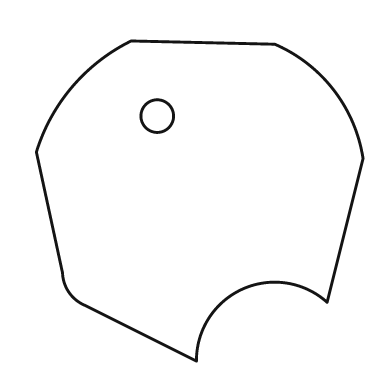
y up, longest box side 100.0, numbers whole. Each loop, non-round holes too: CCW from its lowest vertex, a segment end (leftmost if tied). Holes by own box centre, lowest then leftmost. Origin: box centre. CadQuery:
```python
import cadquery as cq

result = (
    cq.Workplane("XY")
    .moveTo(-1.0, -49.0)
    .threePointArc((13.0, -27.0), (39.0, -31.0))
    .lineTo(50.0, 13.0)
    .threePointArc((41.0, 34.0), (23.0, 48.0))
    .lineTo(-21.0, 49.0)
    .threePointArc((-39.0, 35.0), (-50.0, 15.0))
    .lineTo(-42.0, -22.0)
    .threePointArc((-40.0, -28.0), (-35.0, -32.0))
    .close()
    .moveTo(-13.0, 26.0)
    .circle(5.0)
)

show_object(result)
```